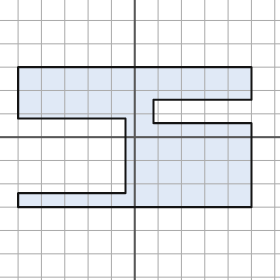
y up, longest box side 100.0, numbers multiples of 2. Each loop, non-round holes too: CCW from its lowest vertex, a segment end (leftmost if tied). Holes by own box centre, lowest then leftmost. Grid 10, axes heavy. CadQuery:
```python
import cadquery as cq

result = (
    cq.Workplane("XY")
    .moveTo(-50.0, -30.0)
    .lineTo(50.0, -30.0)
    .lineTo(50.0, 6.0)
    .lineTo(8.0, 6.0)
    .lineTo(8.0, 16.0)
    .lineTo(50.0, 16.0)
    .lineTo(50.0, 30.0)
    .lineTo(-50.0, 30.0)
    .lineTo(-50.0, 8.0)
    .lineTo(-4.0, 8.0)
    .lineTo(-4.0, -24.0)
    .lineTo(-50.0, -24.0)
    .close()
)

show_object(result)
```